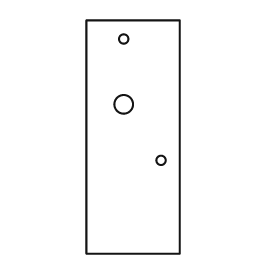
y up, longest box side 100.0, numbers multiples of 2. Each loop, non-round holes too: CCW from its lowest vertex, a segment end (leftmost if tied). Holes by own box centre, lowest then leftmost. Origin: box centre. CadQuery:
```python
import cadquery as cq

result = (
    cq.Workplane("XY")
    .moveTo(-20.0, -50.0)
    .lineTo(20.0, -50.0)
    .lineTo(20.0, 50.0)
    .lineTo(-20.0, 50.0)
    .close()
    .moveTo(12.0, -10.0)
    .circle(2.0)
    .moveTo(-4.0, 14.0)
    .circle(4.0)
    .moveTo(-4.0, 42.0)
    .circle(2.0)
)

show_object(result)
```